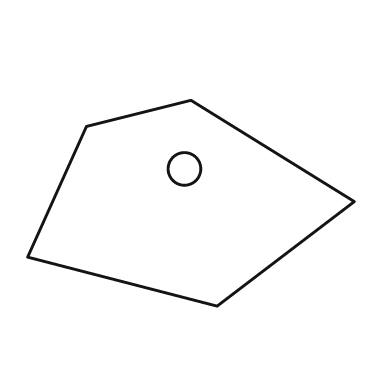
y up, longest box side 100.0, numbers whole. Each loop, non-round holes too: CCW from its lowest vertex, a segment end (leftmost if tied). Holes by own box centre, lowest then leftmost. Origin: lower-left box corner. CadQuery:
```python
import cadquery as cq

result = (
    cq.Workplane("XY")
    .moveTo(58.0, 0.0)
    .lineTo(100.0, 32.0)
    .lineTo(50.0, 63.0)
    .lineTo(18.0, 55.0)
    .lineTo(0.0, 15.0)
    .close()
    .moveTo(48.0, 42.0)
    .circle(5.0)
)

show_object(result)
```